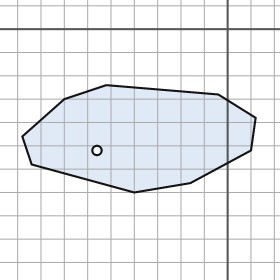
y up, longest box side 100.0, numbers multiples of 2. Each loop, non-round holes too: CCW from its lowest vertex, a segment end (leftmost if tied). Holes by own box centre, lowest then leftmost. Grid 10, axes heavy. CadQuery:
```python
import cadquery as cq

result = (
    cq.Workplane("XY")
    .moveTo(-40.0, -70.0)
    .lineTo(-16.0, -66.0)
    .lineTo(10.0, -52.0)
    .lineTo(12.0, -38.0)
    .lineTo(-4.0, -28.0)
    .lineTo(-52.0, -24.0)
    .lineTo(-70.0, -30.0)
    .lineTo(-88.0, -46.0)
    .lineTo(-84.0, -58.0)
    .close()
    .moveTo(-56.0, -52.0)
    .circle(2.0)
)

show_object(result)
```